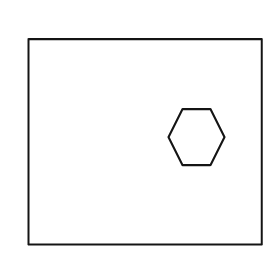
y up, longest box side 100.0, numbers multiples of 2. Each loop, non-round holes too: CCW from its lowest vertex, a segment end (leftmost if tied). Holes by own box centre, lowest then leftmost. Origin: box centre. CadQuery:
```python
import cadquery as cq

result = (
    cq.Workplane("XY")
    .moveTo(-50.0, -44.0)
    .lineTo(50.0, -44.0)
    .lineTo(50.0, 44.0)
    .lineTo(-50.0, 44.0)
    .close()
    .moveTo(16.0, -10.0)
    .lineTo(28.0, -10.0)
    .lineTo(34.0, 2.0)
    .lineTo(28.0, 14.0)
    .lineTo(16.0, 14.0)
    .lineTo(10.0, 2.0)
    .close()
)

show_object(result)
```